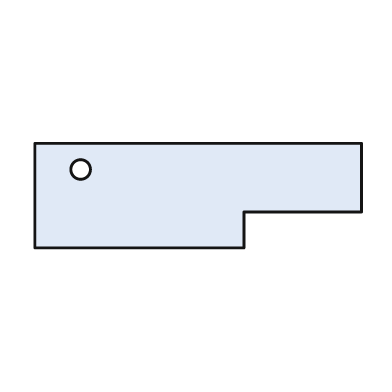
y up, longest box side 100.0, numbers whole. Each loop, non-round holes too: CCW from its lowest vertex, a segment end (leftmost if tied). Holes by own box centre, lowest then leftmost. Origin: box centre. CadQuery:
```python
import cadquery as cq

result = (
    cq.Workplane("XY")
    .moveTo(-50.0, -16.0)
    .lineTo(14.0, -16.0)
    .lineTo(14.0, -5.0)
    .lineTo(50.0, -5.0)
    .lineTo(50.0, 16.0)
    .lineTo(-50.0, 16.0)
    .close()
    .moveTo(-36.0, 8.0)
    .circle(3.0)
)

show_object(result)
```